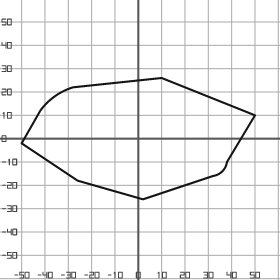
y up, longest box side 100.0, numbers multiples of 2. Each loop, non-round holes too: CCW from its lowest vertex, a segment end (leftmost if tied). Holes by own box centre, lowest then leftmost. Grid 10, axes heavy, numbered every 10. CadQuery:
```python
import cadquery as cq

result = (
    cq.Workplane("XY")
    .moveTo(2.0, -26.0)
    .lineTo(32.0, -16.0)
    .threePointArc((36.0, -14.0), (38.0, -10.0))
    .lineTo(50.0, 10.0)
    .lineTo(10.0, 26.0)
    .lineTo(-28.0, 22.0)
    .threePointArc((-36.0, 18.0), (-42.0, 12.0))
    .lineTo(-50.0, -2.0)
    .lineTo(-26.0, -18.0)
    .close()
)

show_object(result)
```